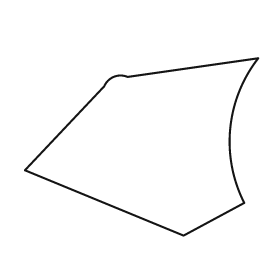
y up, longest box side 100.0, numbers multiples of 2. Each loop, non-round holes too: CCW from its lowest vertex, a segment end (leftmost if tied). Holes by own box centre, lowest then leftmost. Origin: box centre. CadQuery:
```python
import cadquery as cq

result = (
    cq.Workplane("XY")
    .moveTo(18.0, -38.0)
    .lineTo(44.0, -24.0)
    .threePointArc((38.0, 8.0), (50.0, 38.0))
    .lineTo(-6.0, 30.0)
    .threePointArc((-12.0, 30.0), (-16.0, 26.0))
    .lineTo(-50.0, -10.0)
    .close()
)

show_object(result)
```